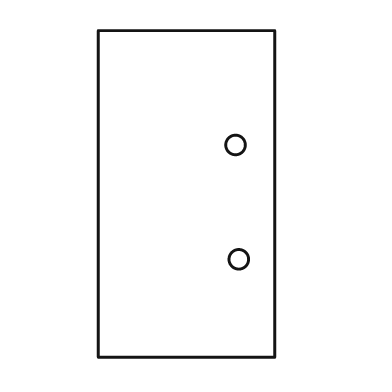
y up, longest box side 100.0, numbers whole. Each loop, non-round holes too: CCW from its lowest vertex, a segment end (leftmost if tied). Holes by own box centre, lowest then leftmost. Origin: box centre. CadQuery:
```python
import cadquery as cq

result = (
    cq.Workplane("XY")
    .moveTo(-27.0, -50.0)
    .lineTo(27.0, -50.0)
    .lineTo(27.0, 50.0)
    .lineTo(-27.0, 50.0)
    .close()
    .moveTo(16.0, -20.0)
    .circle(3.0)
    .moveTo(15.0, 15.0)
    .circle(3.0)
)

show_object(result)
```